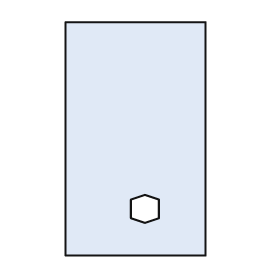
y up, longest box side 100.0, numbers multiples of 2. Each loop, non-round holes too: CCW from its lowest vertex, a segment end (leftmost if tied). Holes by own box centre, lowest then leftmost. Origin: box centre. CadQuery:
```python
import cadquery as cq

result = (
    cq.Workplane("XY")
    .moveTo(-30.0, -50.0)
    .lineTo(30.0, -50.0)
    .lineTo(30.0, 50.0)
    .lineTo(-30.0, 50.0)
    .close()
    .moveTo(4.0, -36.0)
    .lineTo(10.0, -34.0)
    .lineTo(10.0, -26.0)
    .lineTo(4.0, -24.0)
    .lineTo(-2.0, -26.0)
    .lineTo(-2.0, -34.0)
    .close()
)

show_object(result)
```